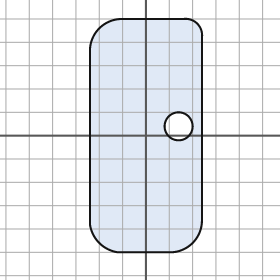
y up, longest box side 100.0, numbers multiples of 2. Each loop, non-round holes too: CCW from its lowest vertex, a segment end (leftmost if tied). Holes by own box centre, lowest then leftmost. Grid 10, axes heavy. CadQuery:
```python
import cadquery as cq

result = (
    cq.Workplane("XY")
    .moveTo(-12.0, -50.0)
    .lineTo(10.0, -50.0)
    .threePointArc((20.0, -46.0), (24.0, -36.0))
    .lineTo(24.0, 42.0)
    .threePointArc((22.0, 48.0), (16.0, 50.0))
    .lineTo(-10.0, 50.0)
    .threePointArc((-20.0, 46.0), (-24.0, 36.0))
    .lineTo(-24.0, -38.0)
    .threePointArc((-20.0, -46.0), (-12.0, -50.0))
    .close()
    .moveTo(14.0, 4.0)
    .circle(6.0)
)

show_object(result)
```